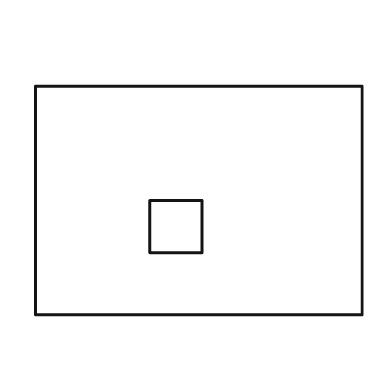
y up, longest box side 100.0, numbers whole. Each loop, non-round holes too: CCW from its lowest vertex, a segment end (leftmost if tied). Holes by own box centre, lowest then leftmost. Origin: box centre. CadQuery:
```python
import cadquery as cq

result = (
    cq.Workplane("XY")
    .moveTo(-50.0, -35.0)
    .lineTo(50.0, -35.0)
    .lineTo(50.0, 35.0)
    .lineTo(-50.0, 35.0)
    .close()
    .moveTo(-15.0, -16.0)
    .lineTo(1.0, -16.0)
    .lineTo(1.0, 0.0)
    .lineTo(-15.0, 0.0)
    .close()
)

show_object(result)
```